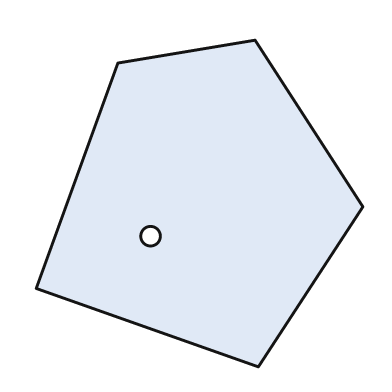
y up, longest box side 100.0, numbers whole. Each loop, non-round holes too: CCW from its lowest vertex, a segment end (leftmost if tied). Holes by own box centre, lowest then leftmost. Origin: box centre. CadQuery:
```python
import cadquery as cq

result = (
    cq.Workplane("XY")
    .moveTo(18.0, -50.0)
    .lineTo(50.0, -1.0)
    .lineTo(17.0, 50.0)
    .lineTo(-25.0, 43.0)
    .lineTo(-50.0, -26.0)
    .close()
    .moveTo(-15.0, -10.0)
    .circle(3.0)
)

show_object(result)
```